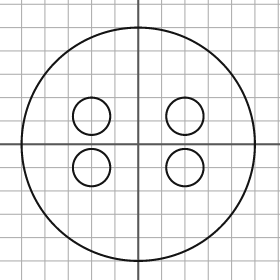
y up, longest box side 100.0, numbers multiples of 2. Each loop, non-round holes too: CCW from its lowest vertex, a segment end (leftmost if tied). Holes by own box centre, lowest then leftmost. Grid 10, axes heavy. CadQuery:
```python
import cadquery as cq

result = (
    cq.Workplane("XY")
    .moveTo(0.0, 0.0)
    .circle(50.0)
    .moveTo(-20.0, -10.0)
    .circle(8.0)
    .moveTo(20.0, -10.0)
    .circle(8.0)
    .moveTo(-20.0, 12.0)
    .circle(8.0)
    .moveTo(20.0, 12.0)
    .circle(8.0)
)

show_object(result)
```